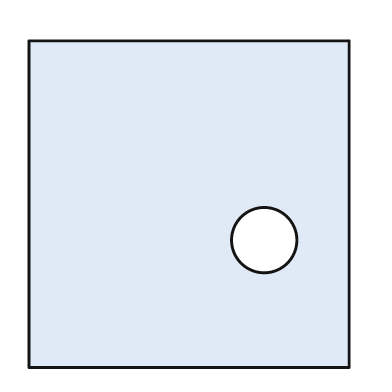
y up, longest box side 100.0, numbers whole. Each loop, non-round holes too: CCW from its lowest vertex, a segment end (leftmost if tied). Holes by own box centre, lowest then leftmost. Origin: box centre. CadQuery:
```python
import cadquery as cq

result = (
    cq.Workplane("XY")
    .moveTo(-49.0, -50.0)
    .lineTo(49.0, -50.0)
    .lineTo(49.0, 50.0)
    .lineTo(-49.0, 50.0)
    .close()
    .moveTo(23.0, -11.0)
    .circle(10.0)
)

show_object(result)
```